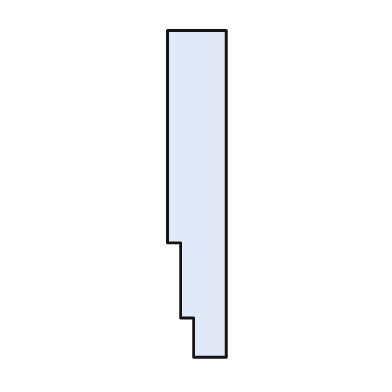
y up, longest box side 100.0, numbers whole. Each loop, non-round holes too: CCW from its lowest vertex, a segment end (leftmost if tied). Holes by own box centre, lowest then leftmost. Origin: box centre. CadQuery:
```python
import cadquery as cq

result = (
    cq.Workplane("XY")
    .moveTo(-1.0, -50.0)
    .lineTo(9.0, -50.0)
    .lineTo(9.0, 50.0)
    .lineTo(-9.0, 50.0)
    .lineTo(-9.0, -15.0)
    .lineTo(-5.0, -15.0)
    .lineTo(-5.0, -38.0)
    .lineTo(-1.0, -38.0)
    .close()
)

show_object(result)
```